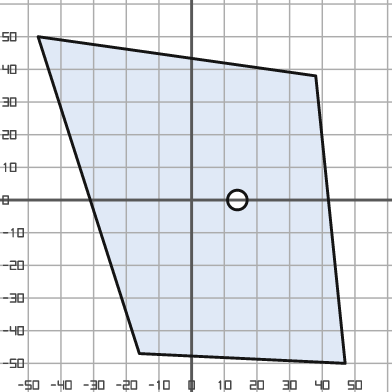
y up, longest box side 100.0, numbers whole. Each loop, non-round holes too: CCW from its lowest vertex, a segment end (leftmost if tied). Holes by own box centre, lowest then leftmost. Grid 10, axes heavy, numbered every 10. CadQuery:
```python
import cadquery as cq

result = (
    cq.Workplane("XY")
    .moveTo(47.0, -50.0)
    .lineTo(38.0, 38.0)
    .lineTo(-47.0, 50.0)
    .lineTo(-16.0, -47.0)
    .close()
    .moveTo(14.0, 0.0)
    .circle(3.0)
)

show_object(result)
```